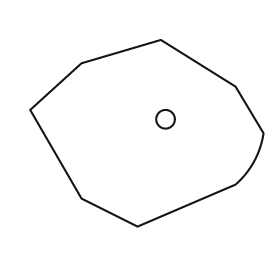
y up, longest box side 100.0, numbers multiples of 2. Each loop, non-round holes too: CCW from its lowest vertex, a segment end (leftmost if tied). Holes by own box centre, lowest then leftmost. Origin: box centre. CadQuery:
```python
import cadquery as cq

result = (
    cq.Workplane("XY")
    .moveTo(-4.0, -40.0)
    .lineTo(38.0, -22.0)
    .threePointArc((46.0, -12.0), (50.0, 0.0))
    .lineTo(38.0, 20.0)
    .lineTo(6.0, 40.0)
    .lineTo(-28.0, 30.0)
    .lineTo(-50.0, 10.0)
    .lineTo(-28.0, -28.0)
    .close()
    .moveTo(8.0, 6.0)
    .circle(4.0)
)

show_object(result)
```